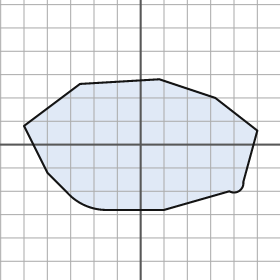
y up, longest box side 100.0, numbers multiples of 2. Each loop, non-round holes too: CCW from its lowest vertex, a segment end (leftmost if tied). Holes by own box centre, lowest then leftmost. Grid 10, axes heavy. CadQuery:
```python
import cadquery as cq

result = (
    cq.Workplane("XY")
    .moveTo(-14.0, -28.0)
    .lineTo(10.0, -28.0)
    .lineTo(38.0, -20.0)
    .threePointArc((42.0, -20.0), (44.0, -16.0))
    .lineTo(50.0, 6.0)
    .lineTo(32.0, 20.0)
    .lineTo(8.0, 28.0)
    .lineTo(-26.0, 26.0)
    .lineTo(-50.0, 8.0)
    .lineTo(-40.0, -12.0)
    .lineTo(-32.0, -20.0)
    .threePointArc((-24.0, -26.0), (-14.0, -28.0))
    .close()
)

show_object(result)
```